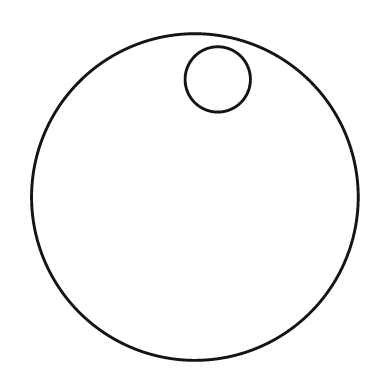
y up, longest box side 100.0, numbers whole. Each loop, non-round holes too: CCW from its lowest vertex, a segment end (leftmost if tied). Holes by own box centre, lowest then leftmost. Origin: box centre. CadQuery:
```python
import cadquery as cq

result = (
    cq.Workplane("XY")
    .moveTo(0.0, 0.0)
    .circle(50.0)
    .moveTo(7.0, 36.0)
    .circle(10.0)
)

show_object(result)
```